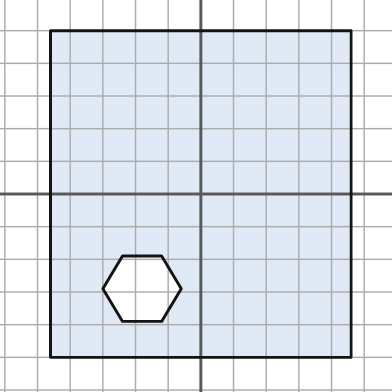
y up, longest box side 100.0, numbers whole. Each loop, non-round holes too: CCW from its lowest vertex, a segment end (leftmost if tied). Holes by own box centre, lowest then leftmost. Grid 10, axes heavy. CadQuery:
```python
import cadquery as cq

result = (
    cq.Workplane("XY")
    .moveTo(-46.0, -50.0)
    .lineTo(46.0, -50.0)
    .lineTo(46.0, 50.0)
    .lineTo(-46.0, 50.0)
    .close()
    .moveTo(-24.0, -39.0)
    .lineTo(-12.0, -39.0)
    .lineTo(-6.0, -29.0)
    .lineTo(-12.0, -19.0)
    .lineTo(-24.0, -19.0)
    .lineTo(-30.0, -29.0)
    .close()
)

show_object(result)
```